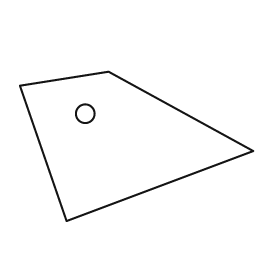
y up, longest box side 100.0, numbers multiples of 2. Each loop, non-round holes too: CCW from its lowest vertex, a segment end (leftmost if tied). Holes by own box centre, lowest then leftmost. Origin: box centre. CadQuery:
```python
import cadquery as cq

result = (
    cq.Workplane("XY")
    .moveTo(-30.0, -32.0)
    .lineTo(50.0, -2.0)
    .lineTo(-12.0, 32.0)
    .lineTo(-50.0, 26.0)
    .close()
    .moveTo(-22.0, 14.0)
    .circle(4.0)
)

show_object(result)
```